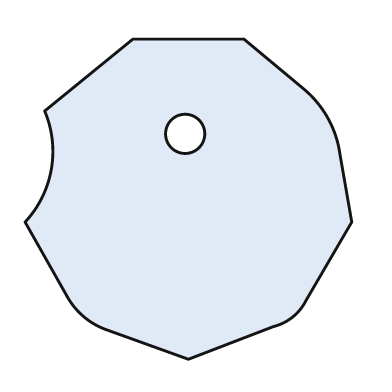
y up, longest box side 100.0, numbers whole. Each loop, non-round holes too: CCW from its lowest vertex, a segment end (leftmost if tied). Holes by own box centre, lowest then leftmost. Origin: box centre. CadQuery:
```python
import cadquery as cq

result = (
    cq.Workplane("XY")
    .moveTo(0.0, -49.0)
    .lineTo(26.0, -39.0)
    .threePointArc((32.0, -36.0), (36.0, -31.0))
    .lineTo(50.0, -7.0)
    .lineTo(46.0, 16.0)
    .threePointArc((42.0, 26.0), (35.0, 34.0))
    .lineTo(17.0, 49.0)
    .lineTo(-17.0, 49.0)
    .lineTo(-44.0, 27.0)
    .threePointArc((-42.0, 9.0), (-50.0, -7.0))
    .lineTo(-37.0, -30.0)
    .threePointArc((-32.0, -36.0), (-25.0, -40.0))
    .close()
    .moveTo(-1.0, 20.0)
    .circle(6.0)
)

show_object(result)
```